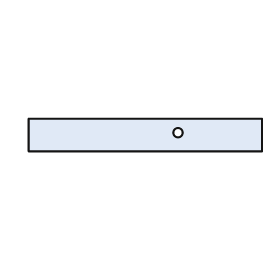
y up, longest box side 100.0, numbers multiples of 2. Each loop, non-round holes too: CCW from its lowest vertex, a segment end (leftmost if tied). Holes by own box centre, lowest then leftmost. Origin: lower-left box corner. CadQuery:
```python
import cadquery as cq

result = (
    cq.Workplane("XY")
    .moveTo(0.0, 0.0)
    .lineTo(100.0, 0.0)
    .lineTo(100.0, 14.0)
    .lineTo(0.0, 14.0)
    .close()
    .moveTo(64.0, 8.0)
    .circle(2.0)
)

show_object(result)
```